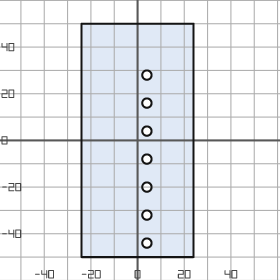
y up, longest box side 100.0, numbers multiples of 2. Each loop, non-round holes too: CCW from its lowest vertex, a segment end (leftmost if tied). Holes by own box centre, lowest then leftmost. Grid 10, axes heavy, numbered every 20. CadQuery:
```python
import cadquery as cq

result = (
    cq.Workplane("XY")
    .moveTo(-24.0, -50.0)
    .lineTo(24.0, -50.0)
    .lineTo(24.0, 50.0)
    .lineTo(-24.0, 50.0)
    .close()
    .moveTo(4.0, -44.0)
    .circle(2.0)
    .moveTo(4.0, -32.0)
    .circle(2.0)
    .moveTo(4.0, -20.0)
    .circle(2.0)
    .moveTo(4.0, -8.0)
    .circle(2.0)
    .moveTo(4.0, 4.0)
    .circle(2.0)
    .moveTo(4.0, 16.0)
    .circle(2.0)
    .moveTo(4.0, 28.0)
    .circle(2.0)
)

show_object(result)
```